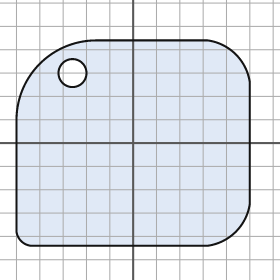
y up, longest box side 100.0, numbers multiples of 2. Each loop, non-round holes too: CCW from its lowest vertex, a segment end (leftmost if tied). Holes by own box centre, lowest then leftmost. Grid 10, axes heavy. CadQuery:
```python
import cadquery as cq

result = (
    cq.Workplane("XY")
    .moveTo(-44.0, -44.0)
    .lineTo(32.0, -44.0)
    .threePointArc((44.0, -38.0), (50.0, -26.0))
    .lineTo(50.0, 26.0)
    .threePointArc((44.0, 38.0), (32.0, 44.0))
    .lineTo(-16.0, 44.0)
    .threePointArc((-40.0, 34.0), (-50.0, 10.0))
    .lineTo(-50.0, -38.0)
    .threePointArc((-48.0, -42.0), (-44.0, -44.0))
    .close()
    .moveTo(-26.0, 30.0)
    .circle(6.0)
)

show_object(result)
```